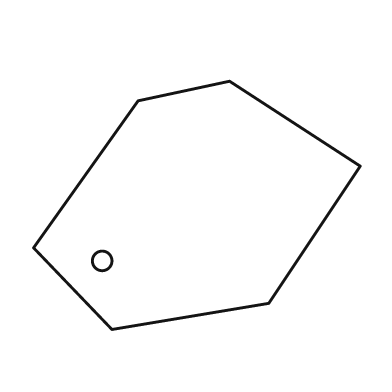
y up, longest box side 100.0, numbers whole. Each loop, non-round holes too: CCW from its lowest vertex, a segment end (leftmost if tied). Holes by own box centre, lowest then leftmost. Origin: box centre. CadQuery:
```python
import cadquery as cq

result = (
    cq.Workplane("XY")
    .moveTo(-26.0, -38.0)
    .lineTo(22.0, -30.0)
    .lineTo(50.0, 12.0)
    .lineTo(10.0, 38.0)
    .lineTo(-18.0, 32.0)
    .lineTo(-50.0, -13.0)
    .close()
    .moveTo(-29.0, -17.0)
    .circle(3.0)
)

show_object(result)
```